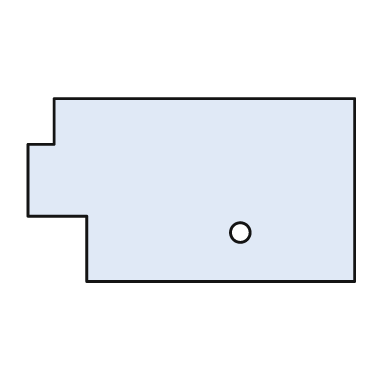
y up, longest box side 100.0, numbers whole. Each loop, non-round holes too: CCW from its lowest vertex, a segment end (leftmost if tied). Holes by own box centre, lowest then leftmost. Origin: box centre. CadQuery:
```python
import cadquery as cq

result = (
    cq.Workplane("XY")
    .moveTo(-32.0, -28.0)
    .lineTo(50.0, -28.0)
    .lineTo(50.0, 28.0)
    .lineTo(-42.0, 28.0)
    .lineTo(-42.0, 14.0)
    .lineTo(-50.0, 14.0)
    .lineTo(-50.0, -8.0)
    .lineTo(-32.0, -8.0)
    .close()
    .moveTo(15.0, -13.0)
    .circle(3.0)
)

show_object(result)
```